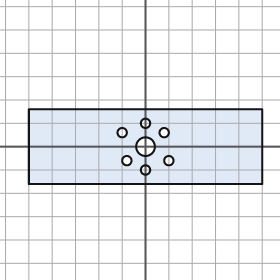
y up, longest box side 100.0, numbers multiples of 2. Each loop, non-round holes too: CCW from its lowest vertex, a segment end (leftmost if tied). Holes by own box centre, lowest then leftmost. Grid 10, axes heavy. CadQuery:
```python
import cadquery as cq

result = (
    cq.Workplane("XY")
    .moveTo(-50.0, -16.0)
    .lineTo(50.0, -16.0)
    .lineTo(50.0, 16.0)
    .lineTo(-50.0, 16.0)
    .close()
    .moveTo(0.0, -10.0)
    .circle(2.0)
    .moveTo(-8.0, -6.0)
    .circle(2.0)
    .moveTo(10.0, -6.0)
    .circle(2.0)
    .moveTo(0.0, 0.0)
    .circle(4.0)
    .moveTo(-10.0, 6.0)
    .circle(2.0)
    .moveTo(8.0, 6.0)
    .circle(2.0)
    .moveTo(0.0, 10.0)
    .circle(2.0)
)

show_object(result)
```